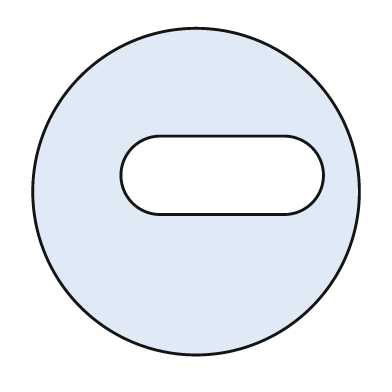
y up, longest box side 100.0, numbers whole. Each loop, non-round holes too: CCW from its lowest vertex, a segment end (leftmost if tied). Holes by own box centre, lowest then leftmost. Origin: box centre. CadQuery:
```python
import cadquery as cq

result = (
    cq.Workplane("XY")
    .moveTo(0.0, 0.0)
    .circle(50.0)
    .moveTo(-11.0, -7.0)
    .lineTo(27.0, -7.0)
    .threePointArc((39.0, 5.0), (27.0, 17.0))
    .lineTo(-11.0, 17.0)
    .threePointArc((-23.0, 5.0), (-11.0, -7.0))
    .close()
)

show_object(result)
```